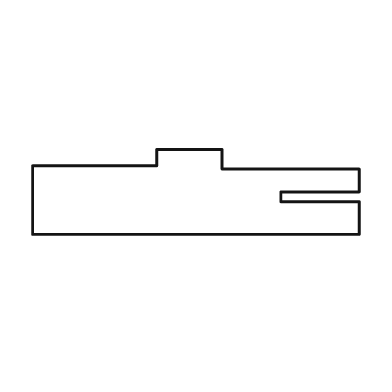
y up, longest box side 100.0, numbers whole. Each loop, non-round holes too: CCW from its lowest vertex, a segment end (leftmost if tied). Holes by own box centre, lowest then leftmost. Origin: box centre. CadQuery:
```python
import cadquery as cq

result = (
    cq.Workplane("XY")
    .moveTo(-50.0, -13.0)
    .lineTo(50.0, -13.0)
    .lineTo(50.0, -3.0)
    .lineTo(26.0, -3.0)
    .lineTo(26.0, 0.0)
    .lineTo(50.0, 0.0)
    .lineTo(50.0, 7.0)
    .lineTo(8.0, 7.0)
    .lineTo(8.0, 13.0)
    .lineTo(-12.0, 13.0)
    .lineTo(-12.0, 8.0)
    .lineTo(-50.0, 8.0)
    .close()
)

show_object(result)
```